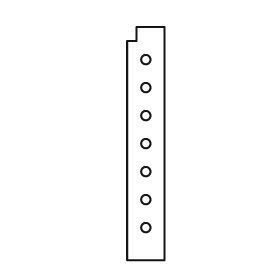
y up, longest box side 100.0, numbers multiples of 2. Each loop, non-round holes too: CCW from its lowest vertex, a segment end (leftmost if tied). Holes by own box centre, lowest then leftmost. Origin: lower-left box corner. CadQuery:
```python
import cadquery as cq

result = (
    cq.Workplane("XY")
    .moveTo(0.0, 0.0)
    .lineTo(16.0, 0.0)
    .lineTo(16.0, 100.0)
    .lineTo(4.0, 100.0)
    .lineTo(4.0, 94.0)
    .lineTo(0.0, 94.0)
    .close()
    .moveTo(8.0, 14.0)
    .circle(2.0)
    .moveTo(8.0, 26.0)
    .circle(2.0)
    .moveTo(8.0, 38.0)
    .circle(2.0)
    .moveTo(8.0, 50.0)
    .circle(2.0)
    .moveTo(8.0, 62.0)
    .circle(2.0)
    .moveTo(8.0, 74.0)
    .circle(2.0)
    .moveTo(8.0, 86.0)
    .circle(2.0)
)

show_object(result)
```